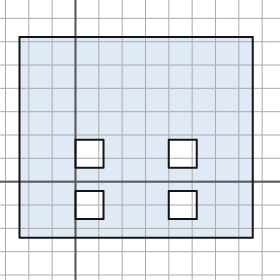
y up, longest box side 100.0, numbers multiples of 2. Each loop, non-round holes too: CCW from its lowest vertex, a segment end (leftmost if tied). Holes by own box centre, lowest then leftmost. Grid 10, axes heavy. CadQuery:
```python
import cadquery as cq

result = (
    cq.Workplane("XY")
    .moveTo(-24.0, -24.0)
    .lineTo(76.0, -24.0)
    .lineTo(76.0, 62.0)
    .lineTo(-24.0, 62.0)
    .close()
    .moveTo(0.0, -16.0)
    .lineTo(12.0, -16.0)
    .lineTo(12.0, -4.0)
    .lineTo(0.0, -4.0)
    .close()
    .moveTo(40.0, -16.0)
    .lineTo(52.0, -16.0)
    .lineTo(52.0, -4.0)
    .lineTo(40.0, -4.0)
    .close()
    .moveTo(0.0, 6.0)
    .lineTo(12.0, 6.0)
    .lineTo(12.0, 18.0)
    .lineTo(0.0, 18.0)
    .close()
    .moveTo(40.0, 6.0)
    .lineTo(52.0, 6.0)
    .lineTo(52.0, 18.0)
    .lineTo(40.0, 18.0)
    .close()
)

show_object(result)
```